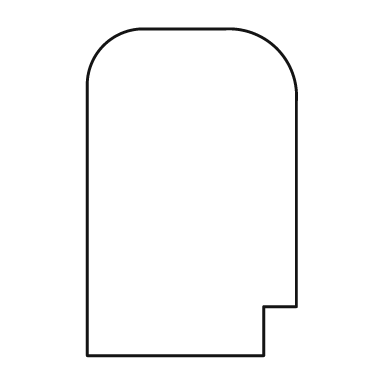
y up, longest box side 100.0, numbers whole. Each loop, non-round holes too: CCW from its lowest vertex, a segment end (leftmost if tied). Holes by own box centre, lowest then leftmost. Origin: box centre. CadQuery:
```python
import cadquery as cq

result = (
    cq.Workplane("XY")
    .moveTo(-32.0, -50.0)
    .lineTo(22.0, -50.0)
    .lineTo(22.0, -35.0)
    .lineTo(32.0, -35.0)
    .lineTo(32.0, 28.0)
    .threePointArc((26.0, 44.0), (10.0, 50.0))
    .lineTo(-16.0, 50.0)
    .threePointArc((-27.0, 45.0), (-32.0, 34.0))
    .close()
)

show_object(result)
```